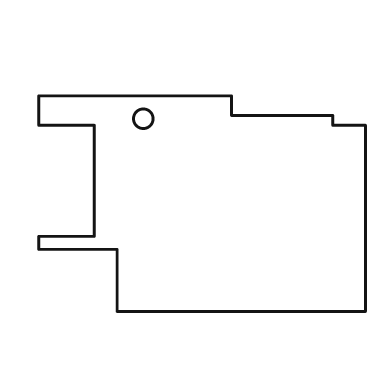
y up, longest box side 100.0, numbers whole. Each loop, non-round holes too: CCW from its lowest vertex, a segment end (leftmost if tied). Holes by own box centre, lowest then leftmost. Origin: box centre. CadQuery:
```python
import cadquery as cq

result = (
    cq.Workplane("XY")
    .moveTo(-26.0, -33.0)
    .lineTo(50.0, -33.0)
    .lineTo(50.0, 24.0)
    .lineTo(40.0, 24.0)
    .lineTo(40.0, 27.0)
    .lineTo(9.0, 27.0)
    .lineTo(9.0, 33.0)
    .lineTo(-50.0, 33.0)
    .lineTo(-50.0, 24.0)
    .lineTo(-33.0, 24.0)
    .lineTo(-33.0, -10.0)
    .lineTo(-50.0, -10.0)
    .lineTo(-50.0, -14.0)
    .lineTo(-26.0, -14.0)
    .close()
    .moveTo(-18.0, 26.0)
    .circle(3.0)
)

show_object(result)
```